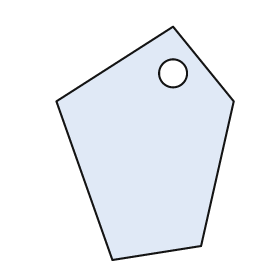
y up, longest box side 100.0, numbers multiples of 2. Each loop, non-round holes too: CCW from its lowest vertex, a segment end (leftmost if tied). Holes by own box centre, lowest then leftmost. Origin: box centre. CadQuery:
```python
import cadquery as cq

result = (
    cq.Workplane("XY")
    .moveTo(-14.0, -50.0)
    .lineTo(24.0, -44.0)
    .lineTo(38.0, 18.0)
    .lineTo(12.0, 50.0)
    .lineTo(-38.0, 18.0)
    .close()
    .moveTo(12.0, 30.0)
    .circle(6.0)
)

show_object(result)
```